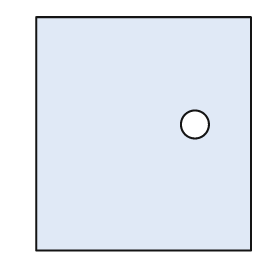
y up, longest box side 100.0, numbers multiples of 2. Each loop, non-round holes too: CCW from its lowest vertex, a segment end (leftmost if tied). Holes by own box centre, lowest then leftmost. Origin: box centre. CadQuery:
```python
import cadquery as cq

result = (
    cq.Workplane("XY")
    .moveTo(-46.0, -50.0)
    .lineTo(46.0, -50.0)
    .lineTo(46.0, 50.0)
    .lineTo(-46.0, 50.0)
    .close()
    .moveTo(22.0, 4.0)
    .circle(6.0)
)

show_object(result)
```